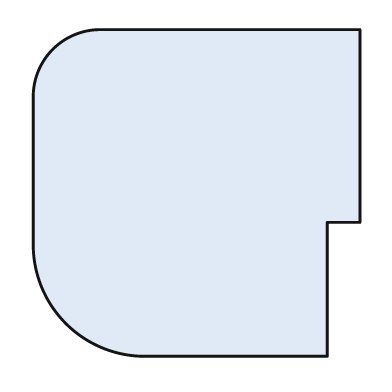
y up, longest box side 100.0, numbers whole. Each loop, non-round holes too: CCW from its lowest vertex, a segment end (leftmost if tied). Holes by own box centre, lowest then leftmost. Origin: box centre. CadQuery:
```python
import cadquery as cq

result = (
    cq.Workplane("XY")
    .moveTo(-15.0, -50.0)
    .lineTo(40.0, -50.0)
    .lineTo(40.0, -9.0)
    .lineTo(50.0, -9.0)
    .lineTo(50.0, 50.0)
    .lineTo(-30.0, 50.0)
    .threePointArc((-44.0, 44.0), (-50.0, 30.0))
    .lineTo(-50.0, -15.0)
    .threePointArc((-40.0, -40.0), (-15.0, -50.0))
    .close()
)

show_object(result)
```